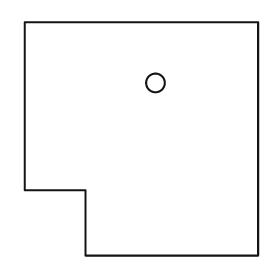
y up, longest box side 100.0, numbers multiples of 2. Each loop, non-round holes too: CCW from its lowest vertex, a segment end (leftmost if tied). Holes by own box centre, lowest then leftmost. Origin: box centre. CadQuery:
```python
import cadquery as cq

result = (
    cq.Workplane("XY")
    .moveTo(-24.0, -50.0)
    .lineTo(50.0, -50.0)
    .lineTo(50.0, 50.0)
    .lineTo(-50.0, 50.0)
    .lineTo(-50.0, -22.0)
    .lineTo(-24.0, -22.0)
    .close()
    .moveTo(6.0, 24.0)
    .circle(4.0)
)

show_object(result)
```